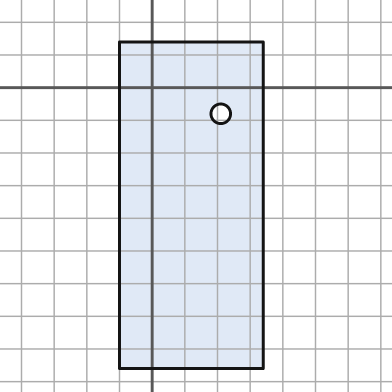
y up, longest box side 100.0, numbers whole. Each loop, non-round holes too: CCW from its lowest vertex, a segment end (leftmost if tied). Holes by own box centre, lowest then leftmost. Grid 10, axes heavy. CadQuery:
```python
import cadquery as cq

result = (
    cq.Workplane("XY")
    .moveTo(-10.0, -86.0)
    .lineTo(34.0, -86.0)
    .lineTo(34.0, 14.0)
    .lineTo(-10.0, 14.0)
    .close()
    .moveTo(21.0, -8.0)
    .circle(3.0)
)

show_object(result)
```